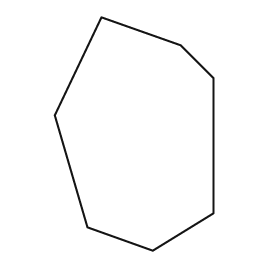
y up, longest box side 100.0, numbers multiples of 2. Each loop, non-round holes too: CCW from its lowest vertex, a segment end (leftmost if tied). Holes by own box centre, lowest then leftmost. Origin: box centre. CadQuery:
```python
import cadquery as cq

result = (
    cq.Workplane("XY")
    .moveTo(8.0, -50.0)
    .lineTo(34.0, -34.0)
    .lineTo(34.0, 24.0)
    .lineTo(20.0, 38.0)
    .lineTo(-14.0, 50.0)
    .lineTo(-34.0, 8.0)
    .lineTo(-20.0, -40.0)
    .close()
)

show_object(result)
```